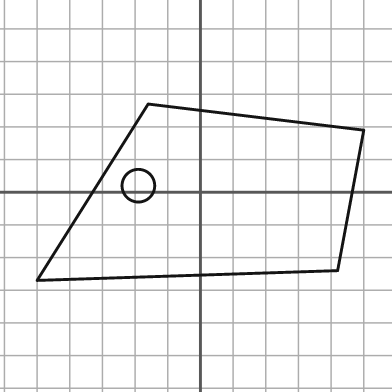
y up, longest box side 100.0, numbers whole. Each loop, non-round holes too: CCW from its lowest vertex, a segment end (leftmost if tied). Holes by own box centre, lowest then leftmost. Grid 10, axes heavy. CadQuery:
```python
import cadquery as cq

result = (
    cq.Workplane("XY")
    .moveTo(-50.0, -27.0)
    .lineTo(42.0, -24.0)
    .lineTo(50.0, 19.0)
    .lineTo(-16.0, 27.0)
    .close()
    .moveTo(-19.0, 2.0)
    .circle(5.0)
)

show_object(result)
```